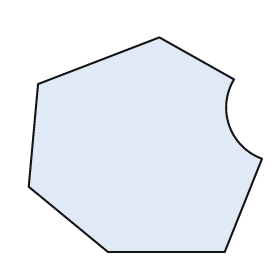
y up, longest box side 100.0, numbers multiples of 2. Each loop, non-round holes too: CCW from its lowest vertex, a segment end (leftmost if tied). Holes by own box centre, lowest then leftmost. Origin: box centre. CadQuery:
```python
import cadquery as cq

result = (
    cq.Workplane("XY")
    .moveTo(-16.0, -46.0)
    .lineTo(34.0, -46.0)
    .lineTo(50.0, -6.0)
    .threePointArc((36.0, 8.0), (38.0, 28.0))
    .lineTo(6.0, 46.0)
    .lineTo(-46.0, 26.0)
    .lineTo(-50.0, -18.0)
    .close()
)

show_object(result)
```